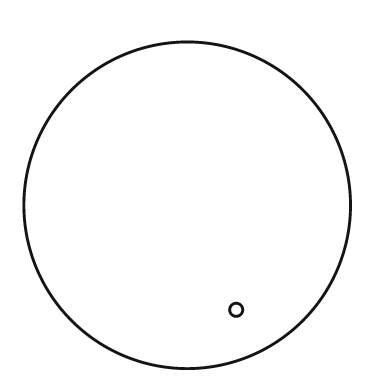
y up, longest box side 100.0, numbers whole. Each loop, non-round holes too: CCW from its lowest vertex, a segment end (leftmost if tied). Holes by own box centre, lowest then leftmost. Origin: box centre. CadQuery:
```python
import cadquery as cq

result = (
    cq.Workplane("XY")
    .moveTo(0.0, 0.0)
    .circle(50.0)
    .moveTo(15.0, -32.0)
    .circle(2.0)
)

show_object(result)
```